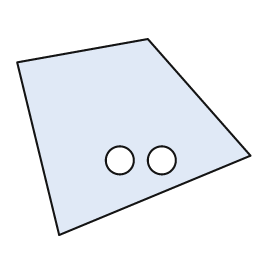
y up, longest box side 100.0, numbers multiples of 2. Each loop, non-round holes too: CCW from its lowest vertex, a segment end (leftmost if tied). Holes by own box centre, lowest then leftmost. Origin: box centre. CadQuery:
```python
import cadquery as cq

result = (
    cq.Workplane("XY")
    .moveTo(-32.0, -42.0)
    .lineTo(50.0, -8.0)
    .lineTo(6.0, 42.0)
    .lineTo(-50.0, 32.0)
    .close()
    .moveTo(-6.0, -10.0)
    .circle(6.0)
    .moveTo(12.0, -10.0)
    .circle(6.0)
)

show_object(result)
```